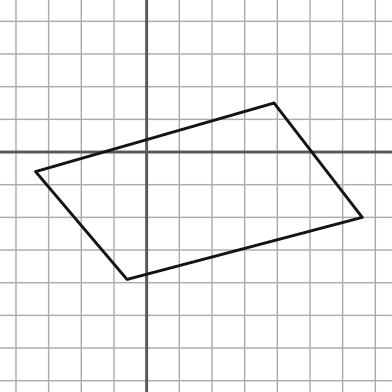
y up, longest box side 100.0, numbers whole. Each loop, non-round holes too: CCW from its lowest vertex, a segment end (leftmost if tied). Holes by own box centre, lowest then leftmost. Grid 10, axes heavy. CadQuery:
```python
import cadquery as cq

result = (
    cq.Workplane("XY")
    .moveTo(-6.0, -39.0)
    .lineTo(66.0, -20.0)
    .lineTo(39.0, 15.0)
    .lineTo(-34.0, -6.0)
    .close()
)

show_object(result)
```